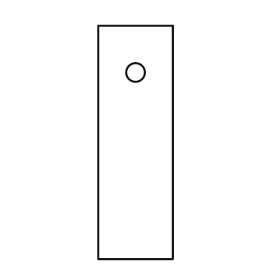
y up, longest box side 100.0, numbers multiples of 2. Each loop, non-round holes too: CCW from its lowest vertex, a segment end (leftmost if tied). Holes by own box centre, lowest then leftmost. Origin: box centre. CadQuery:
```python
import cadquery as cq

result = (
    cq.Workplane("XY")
    .moveTo(-16.0, -50.0)
    .lineTo(16.0, -50.0)
    .lineTo(16.0, 50.0)
    .lineTo(-16.0, 50.0)
    .close()
    .moveTo(0.0, 30.0)
    .circle(4.0)
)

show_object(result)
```